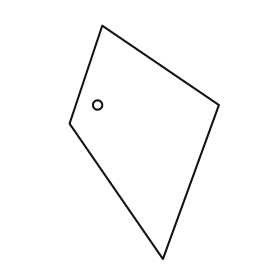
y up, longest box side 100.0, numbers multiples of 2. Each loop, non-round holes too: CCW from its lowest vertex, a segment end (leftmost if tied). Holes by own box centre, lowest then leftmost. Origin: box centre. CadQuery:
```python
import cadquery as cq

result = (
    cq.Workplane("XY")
    .moveTo(8.0, -50.0)
    .lineTo(32.0, 16.0)
    .lineTo(-18.0, 50.0)
    .lineTo(-32.0, 8.0)
    .close()
    .moveTo(-20.0, 16.0)
    .circle(2.0)
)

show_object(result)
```